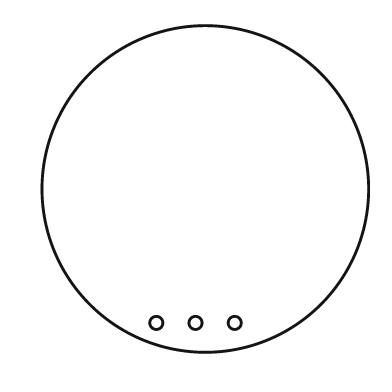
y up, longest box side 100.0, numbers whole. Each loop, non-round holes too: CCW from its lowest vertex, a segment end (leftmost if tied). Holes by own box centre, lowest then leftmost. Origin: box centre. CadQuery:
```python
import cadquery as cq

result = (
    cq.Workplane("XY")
    .moveTo(0.0, 0.0)
    .circle(50.0)
    .moveTo(-15.0, -41.0)
    .circle(2.0)
    .moveTo(-3.0, -41.0)
    .circle(2.0)
    .moveTo(9.0, -41.0)
    .circle(2.0)
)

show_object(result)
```